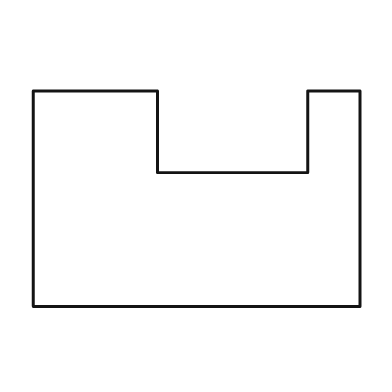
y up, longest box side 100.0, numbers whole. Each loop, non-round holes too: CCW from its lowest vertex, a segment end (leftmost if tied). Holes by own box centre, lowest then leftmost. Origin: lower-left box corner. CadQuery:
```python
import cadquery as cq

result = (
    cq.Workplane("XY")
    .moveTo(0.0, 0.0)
    .lineTo(100.0, 0.0)
    .lineTo(100.0, 66.0)
    .lineTo(84.0, 66.0)
    .lineTo(84.0, 41.0)
    .lineTo(38.0, 41.0)
    .lineTo(38.0, 66.0)
    .lineTo(0.0, 66.0)
    .close()
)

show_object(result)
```